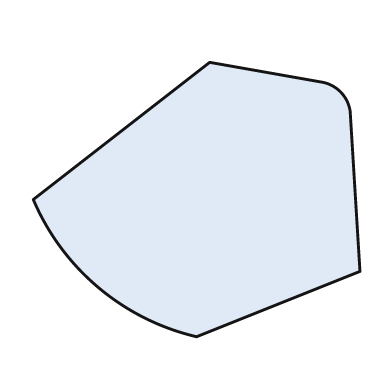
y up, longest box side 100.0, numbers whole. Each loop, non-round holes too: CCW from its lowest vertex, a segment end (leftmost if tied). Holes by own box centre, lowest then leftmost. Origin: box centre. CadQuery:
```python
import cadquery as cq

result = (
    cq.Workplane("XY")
    .moveTo(0.0, -42.0)
    .lineTo(50.0, -22.0)
    .lineTo(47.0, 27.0)
    .threePointArc((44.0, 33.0), (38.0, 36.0))
    .lineTo(4.0, 42.0)
    .lineTo(-50.0, 0.0)
    .threePointArc((-30.0, -27.0), (0.0, -42.0))
    .close()
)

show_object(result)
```